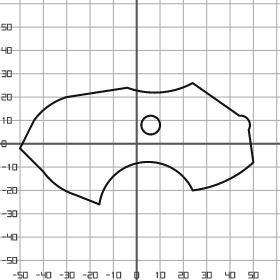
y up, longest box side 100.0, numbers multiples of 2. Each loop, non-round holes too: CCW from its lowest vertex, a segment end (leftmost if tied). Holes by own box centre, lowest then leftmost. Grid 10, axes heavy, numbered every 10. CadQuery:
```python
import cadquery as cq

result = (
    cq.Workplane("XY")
    .moveTo(-16.0, -26.0)
    .threePointArc((2.0, -8.0), (24.0, -20.0))
    .threePointArc((38.0, -16.0), (50.0, -8.0))
    .lineTo(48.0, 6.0)
    .threePointArc((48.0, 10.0), (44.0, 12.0))
    .lineTo(24.0, 26.0)
    .threePointArc((10.0, 22.0), (-4.0, 24.0))
    .lineTo(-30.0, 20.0)
    .threePointArc((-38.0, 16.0), (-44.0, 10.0))
    .lineTo(-50.0, -2.0)
    .lineTo(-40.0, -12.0)
    .threePointArc((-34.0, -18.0), (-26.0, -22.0))
    .close()
    .moveTo(6.0, 8.0)
    .circle(4.0)
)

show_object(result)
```